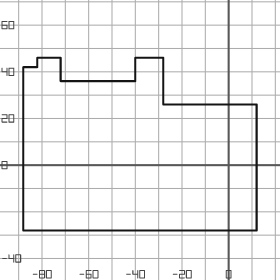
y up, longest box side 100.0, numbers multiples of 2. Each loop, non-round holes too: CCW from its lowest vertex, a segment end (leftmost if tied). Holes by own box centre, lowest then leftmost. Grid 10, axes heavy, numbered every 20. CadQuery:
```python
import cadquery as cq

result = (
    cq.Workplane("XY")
    .moveTo(-88.0, -28.0)
    .lineTo(12.0, -28.0)
    .lineTo(12.0, 26.0)
    .lineTo(-28.0, 26.0)
    .lineTo(-28.0, 46.0)
    .lineTo(-40.0, 46.0)
    .lineTo(-40.0, 36.0)
    .lineTo(-72.0, 36.0)
    .lineTo(-72.0, 46.0)
    .lineTo(-82.0, 46.0)
    .lineTo(-82.0, 42.0)
    .lineTo(-88.0, 42.0)
    .close()
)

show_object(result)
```